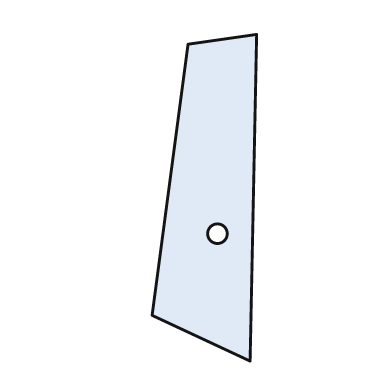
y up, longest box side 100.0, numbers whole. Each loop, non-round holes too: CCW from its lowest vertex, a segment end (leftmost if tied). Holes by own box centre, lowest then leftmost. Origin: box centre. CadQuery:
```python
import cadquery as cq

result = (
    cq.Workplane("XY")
    .moveTo(14.0, -50.0)
    .lineTo(16.0, 50.0)
    .lineTo(-5.0, 47.0)
    .lineTo(-16.0, -36.0)
    .close()
    .moveTo(4.0, -11.0)
    .circle(3.0)
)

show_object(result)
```